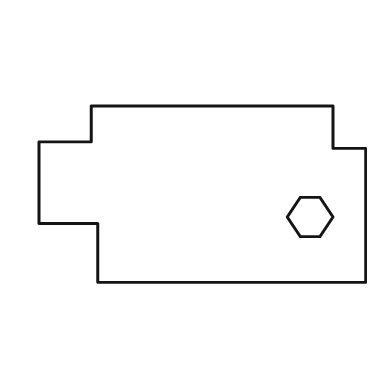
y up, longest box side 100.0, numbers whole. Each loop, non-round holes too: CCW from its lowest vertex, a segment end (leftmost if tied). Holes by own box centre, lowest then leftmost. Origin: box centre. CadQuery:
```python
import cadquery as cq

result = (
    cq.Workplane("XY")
    .moveTo(-32.0, -27.0)
    .lineTo(50.0, -27.0)
    .lineTo(50.0, 14.0)
    .lineTo(40.0, 14.0)
    .lineTo(40.0, 27.0)
    .lineTo(-34.0, 27.0)
    .lineTo(-34.0, 16.0)
    .lineTo(-50.0, 16.0)
    .lineTo(-50.0, -9.0)
    .lineTo(-32.0, -9.0)
    .close()
    .moveTo(30.0, -13.0)
    .lineTo(36.0, -13.0)
    .lineTo(40.0, -7.0)
    .lineTo(36.0, -1.0)
    .lineTo(30.0, -1.0)
    .lineTo(26.0, -7.0)
    .close()
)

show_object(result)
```